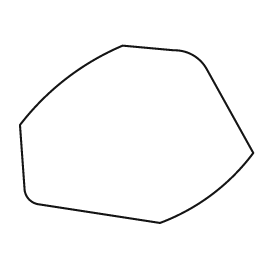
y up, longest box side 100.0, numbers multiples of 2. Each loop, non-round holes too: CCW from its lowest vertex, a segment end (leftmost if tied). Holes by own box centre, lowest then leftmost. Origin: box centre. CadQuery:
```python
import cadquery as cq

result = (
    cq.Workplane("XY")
    .moveTo(10.0, -38.0)
    .threePointArc((32.0, -26.0), (50.0, -8.0))
    .lineTo(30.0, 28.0)
    .threePointArc((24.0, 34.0), (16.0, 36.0))
    .lineTo(-6.0, 38.0)
    .threePointArc((-30.0, 24.0), (-50.0, 4.0))
    .lineTo(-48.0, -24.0)
    .threePointArc((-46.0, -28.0), (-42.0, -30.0))
    .close()
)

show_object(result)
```